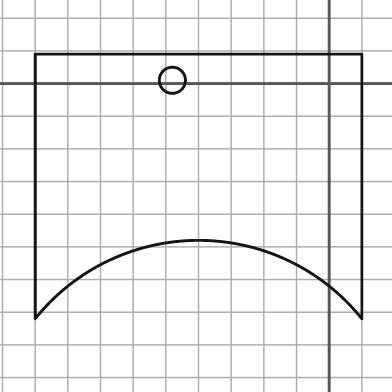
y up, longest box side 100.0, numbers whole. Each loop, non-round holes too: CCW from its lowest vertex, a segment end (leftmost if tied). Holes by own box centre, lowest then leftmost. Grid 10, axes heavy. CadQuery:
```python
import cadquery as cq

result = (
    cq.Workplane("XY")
    .moveTo(-90.0, -72.0)
    .threePointArc((-40.0, -48.0), (10.0, -72.0))
    .lineTo(10.0, 9.0)
    .lineTo(-90.0, 9.0)
    .close()
    .moveTo(-48.0, 1.0)
    .circle(4.0)
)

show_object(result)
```